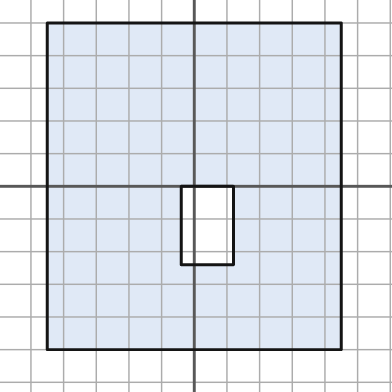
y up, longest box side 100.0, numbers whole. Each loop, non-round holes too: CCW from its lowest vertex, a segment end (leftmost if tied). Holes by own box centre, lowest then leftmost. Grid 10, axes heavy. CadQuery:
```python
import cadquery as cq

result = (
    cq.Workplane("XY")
    .moveTo(-45.0, -50.0)
    .lineTo(45.0, -50.0)
    .lineTo(45.0, 50.0)
    .lineTo(-45.0, 50.0)
    .close()
    .moveTo(-4.0, -24.0)
    .lineTo(12.0, -24.0)
    .lineTo(12.0, 0.0)
    .lineTo(-4.0, 0.0)
    .close()
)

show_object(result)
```